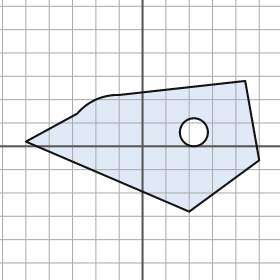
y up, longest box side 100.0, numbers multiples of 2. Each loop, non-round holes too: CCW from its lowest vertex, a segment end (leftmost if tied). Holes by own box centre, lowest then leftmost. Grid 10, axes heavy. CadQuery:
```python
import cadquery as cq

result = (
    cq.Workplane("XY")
    .moveTo(20.0, -28.0)
    .lineTo(50.0, -6.0)
    .lineTo(44.0, 28.0)
    .lineTo(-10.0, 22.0)
    .threePointArc((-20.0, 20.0), (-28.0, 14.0))
    .lineTo(-50.0, 2.0)
    .close()
    .moveTo(22.0, 6.0)
    .circle(6.0)
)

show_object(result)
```